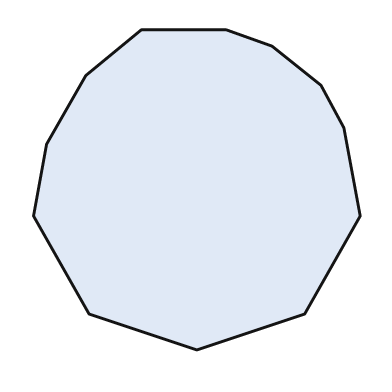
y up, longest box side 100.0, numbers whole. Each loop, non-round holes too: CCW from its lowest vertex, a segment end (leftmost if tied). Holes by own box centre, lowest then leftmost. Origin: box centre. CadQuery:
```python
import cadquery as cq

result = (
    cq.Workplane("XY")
    .moveTo(0.0, -49.0)
    .lineTo(33.0, -38.0)
    .lineTo(50.0, -8.0)
    .lineTo(45.0, 19.0)
    .lineTo(38.0, 32.0)
    .lineTo(23.0, 44.0)
    .lineTo(9.0, 49.0)
    .lineTo(-17.0, 49.0)
    .lineTo(-34.0, 35.0)
    .lineTo(-46.0, 14.0)
    .lineTo(-50.0, -8.0)
    .lineTo(-33.0, -38.0)
    .close()
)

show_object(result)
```